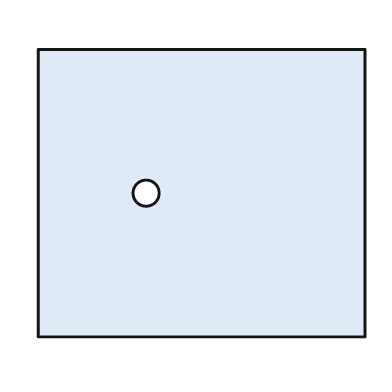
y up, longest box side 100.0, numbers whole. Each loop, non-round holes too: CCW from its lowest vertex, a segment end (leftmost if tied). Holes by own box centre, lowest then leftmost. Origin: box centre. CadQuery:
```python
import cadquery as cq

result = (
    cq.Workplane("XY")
    .moveTo(-50.0, -44.0)
    .lineTo(50.0, -44.0)
    .lineTo(50.0, 44.0)
    .lineTo(-50.0, 44.0)
    .close()
    .moveTo(-17.0, 0.0)
    .circle(4.0)
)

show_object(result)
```